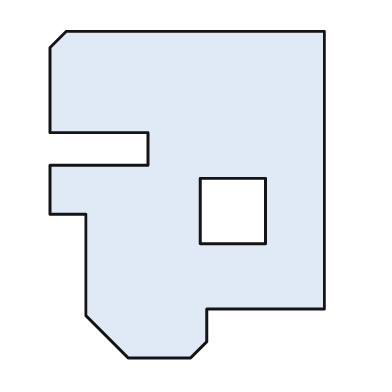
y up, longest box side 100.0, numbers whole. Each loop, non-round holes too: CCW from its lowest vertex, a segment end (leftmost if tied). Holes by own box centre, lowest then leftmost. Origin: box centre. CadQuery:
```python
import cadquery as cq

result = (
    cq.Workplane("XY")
    .moveTo(-18.0, -50.0)
    .lineTo(1.0, -50.0)
    .lineTo(6.0, -45.0)
    .lineTo(6.0, -35.0)
    .lineTo(42.0, -35.0)
    .lineTo(42.0, 50.0)
    .lineTo(-37.0, 50.0)
    .lineTo(-42.0, 45.0)
    .lineTo(-42.0, 19.0)
    .lineTo(-12.0, 19.0)
    .lineTo(-12.0, 9.0)
    .lineTo(-42.0, 9.0)
    .lineTo(-42.0, -6.0)
    .lineTo(-31.0, -6.0)
    .lineTo(-31.0, -37.0)
    .close()
    .moveTo(4.0, -15.0)
    .lineTo(24.0, -15.0)
    .lineTo(24.0, 5.0)
    .lineTo(4.0, 5.0)
    .close()
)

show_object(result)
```